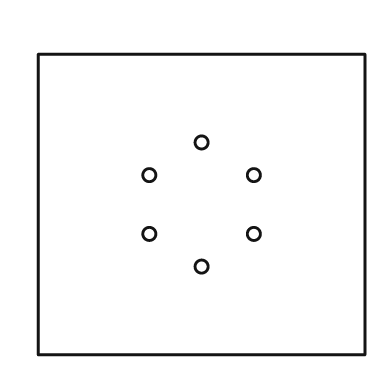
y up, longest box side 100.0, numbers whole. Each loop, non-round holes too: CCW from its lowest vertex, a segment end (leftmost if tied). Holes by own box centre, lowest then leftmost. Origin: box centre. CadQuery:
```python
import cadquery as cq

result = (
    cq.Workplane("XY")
    .moveTo(-50.0, -46.0)
    .lineTo(50.0, -46.0)
    .lineTo(50.0, 46.0)
    .lineTo(-50.0, 46.0)
    .close()
    .moveTo(0.0, -19.0)
    .circle(2.0)
    .moveTo(-16.0, -9.0)
    .circle(2.0)
    .moveTo(16.0, -9.0)
    .circle(2.0)
    .moveTo(-16.0, 9.0)
    .circle(2.0)
    .moveTo(16.0, 9.0)
    .circle(2.0)
    .moveTo(0.0, 19.0)
    .circle(2.0)
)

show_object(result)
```